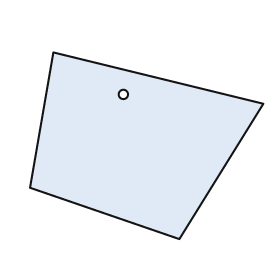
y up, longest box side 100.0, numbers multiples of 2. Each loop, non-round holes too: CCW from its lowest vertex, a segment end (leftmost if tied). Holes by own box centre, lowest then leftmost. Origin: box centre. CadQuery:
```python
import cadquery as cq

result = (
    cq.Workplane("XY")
    .moveTo(14.0, -40.0)
    .lineTo(50.0, 18.0)
    .lineTo(-40.0, 40.0)
    .lineTo(-50.0, -18.0)
    .close()
    .moveTo(-10.0, 22.0)
    .circle(2.0)
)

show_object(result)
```